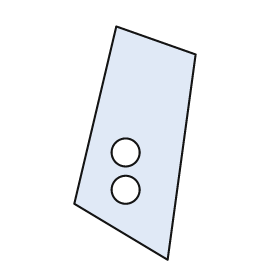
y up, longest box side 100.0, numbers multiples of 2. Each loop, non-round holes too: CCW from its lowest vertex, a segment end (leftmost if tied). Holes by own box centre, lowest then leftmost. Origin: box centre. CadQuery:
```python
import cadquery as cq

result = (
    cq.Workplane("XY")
    .moveTo(14.0, -50.0)
    .lineTo(26.0, 38.0)
    .lineTo(-8.0, 50.0)
    .lineTo(-26.0, -26.0)
    .close()
    .moveTo(-4.0, -20.0)
    .circle(6.0)
    .moveTo(-4.0, -4.0)
    .circle(6.0)
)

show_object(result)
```